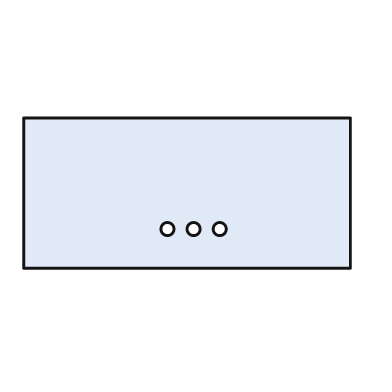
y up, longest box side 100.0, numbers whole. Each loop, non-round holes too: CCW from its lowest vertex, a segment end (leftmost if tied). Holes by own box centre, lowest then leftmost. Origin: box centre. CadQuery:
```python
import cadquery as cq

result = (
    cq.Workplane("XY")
    .moveTo(-50.0, -23.0)
    .lineTo(50.0, -23.0)
    .lineTo(50.0, 23.0)
    .lineTo(-50.0, 23.0)
    .close()
    .moveTo(-6.0, -11.0)
    .circle(2.0)
    .moveTo(2.0, -11.0)
    .circle(2.0)
    .moveTo(10.0, -11.0)
    .circle(2.0)
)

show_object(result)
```